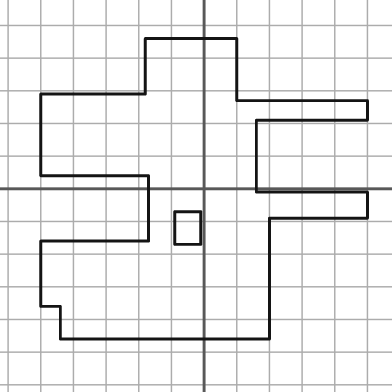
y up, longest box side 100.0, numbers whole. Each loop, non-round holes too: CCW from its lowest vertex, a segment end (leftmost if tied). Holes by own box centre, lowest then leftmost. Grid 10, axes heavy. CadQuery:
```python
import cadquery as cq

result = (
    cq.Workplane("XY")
    .moveTo(-44.0, -46.0)
    .lineTo(20.0, -46.0)
    .lineTo(20.0, -9.0)
    .lineTo(50.0, -9.0)
    .lineTo(50.0, -1.0)
    .lineTo(16.0, -1.0)
    .lineTo(16.0, 21.0)
    .lineTo(50.0, 21.0)
    .lineTo(50.0, 27.0)
    .lineTo(10.0, 27.0)
    .lineTo(10.0, 46.0)
    .lineTo(-18.0, 46.0)
    .lineTo(-18.0, 29.0)
    .lineTo(-50.0, 29.0)
    .lineTo(-50.0, 4.0)
    .lineTo(-17.0, 4.0)
    .lineTo(-17.0, -16.0)
    .lineTo(-50.0, -16.0)
    .lineTo(-50.0, -36.0)
    .lineTo(-44.0, -36.0)
    .close()
    .moveTo(-9.0, -17.0)
    .lineTo(-1.0, -17.0)
    .lineTo(-1.0, -7.0)
    .lineTo(-9.0, -7.0)
    .close()
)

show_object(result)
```